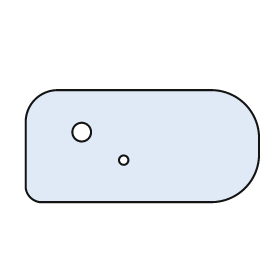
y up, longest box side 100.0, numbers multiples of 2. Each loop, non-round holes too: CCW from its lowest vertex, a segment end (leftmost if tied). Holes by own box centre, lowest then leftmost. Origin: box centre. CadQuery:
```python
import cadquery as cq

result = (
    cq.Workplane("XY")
    .moveTo(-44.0, -24.0)
    .lineTo(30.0, -24.0)
    .threePointArc((44.0, -18.0), (50.0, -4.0))
    .lineTo(50.0, 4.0)
    .threePointArc((44.0, 18.0), (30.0, 24.0))
    .lineTo(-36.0, 24.0)
    .threePointArc((-46.0, 20.0), (-50.0, 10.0))
    .lineTo(-50.0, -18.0)
    .threePointArc((-48.0, -22.0), (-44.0, -24.0))
    .close()
    .moveTo(-8.0, -6.0)
    .circle(2.0)
    .moveTo(-26.0, 6.0)
    .circle(4.0)
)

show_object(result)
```